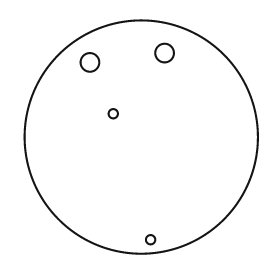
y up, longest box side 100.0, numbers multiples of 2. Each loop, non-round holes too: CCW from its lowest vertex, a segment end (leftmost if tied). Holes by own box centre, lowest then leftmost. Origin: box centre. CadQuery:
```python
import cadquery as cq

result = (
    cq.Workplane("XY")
    .moveTo(0.0, 0.0)
    .circle(50.0)
    .moveTo(4.0, -44.0)
    .circle(2.0)
    .moveTo(-12.0, 10.0)
    .circle(2.0)
    .moveTo(-22.0, 32.0)
    .circle(4.0)
    .moveTo(10.0, 36.0)
    .circle(4.0)
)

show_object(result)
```